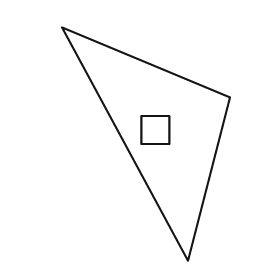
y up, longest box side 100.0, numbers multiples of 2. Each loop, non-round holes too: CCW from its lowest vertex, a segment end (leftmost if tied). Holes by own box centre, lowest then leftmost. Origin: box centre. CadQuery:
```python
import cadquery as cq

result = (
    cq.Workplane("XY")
    .moveTo(18.0, -50.0)
    .lineTo(36.0, 20.0)
    .lineTo(-36.0, 50.0)
    .close()
    .moveTo(-2.0, 0.0)
    .lineTo(10.0, 0.0)
    .lineTo(10.0, 12.0)
    .lineTo(-2.0, 12.0)
    .close()
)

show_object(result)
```